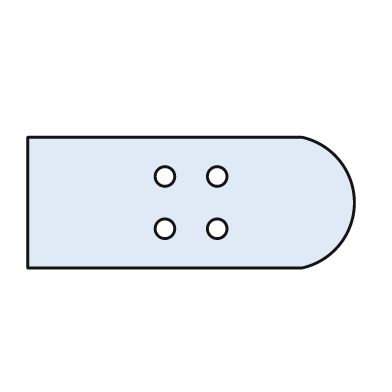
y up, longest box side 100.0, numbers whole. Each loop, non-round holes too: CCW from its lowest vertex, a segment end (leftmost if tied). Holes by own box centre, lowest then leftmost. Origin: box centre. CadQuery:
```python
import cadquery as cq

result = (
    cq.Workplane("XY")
    .moveTo(-50.0, -20.0)
    .lineTo(34.0, -20.0)
    .threePointArc((50.0, 0.0), (34.0, 20.0))
    .lineTo(-50.0, 20.0)
    .close()
    .moveTo(-8.0, -8.0)
    .circle(3.0)
    .moveTo(8.0, -8.0)
    .circle(3.0)
    .moveTo(-8.0, 8.0)
    .circle(3.0)
    .moveTo(8.0, 8.0)
    .circle(3.0)
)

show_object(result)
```